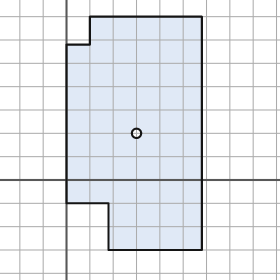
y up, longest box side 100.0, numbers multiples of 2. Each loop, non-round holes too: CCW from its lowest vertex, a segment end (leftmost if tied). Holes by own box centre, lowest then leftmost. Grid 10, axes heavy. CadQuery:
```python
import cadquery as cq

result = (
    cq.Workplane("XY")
    .moveTo(18.0, -30.0)
    .lineTo(58.0, -30.0)
    .lineTo(58.0, 70.0)
    .lineTo(10.0, 70.0)
    .lineTo(10.0, 58.0)
    .lineTo(0.0, 58.0)
    .lineTo(0.0, -10.0)
    .lineTo(18.0, -10.0)
    .close()
    .moveTo(30.0, 20.0)
    .circle(2.0)
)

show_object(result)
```